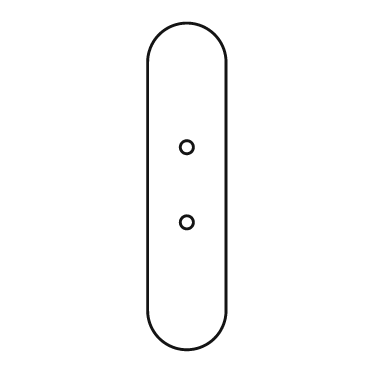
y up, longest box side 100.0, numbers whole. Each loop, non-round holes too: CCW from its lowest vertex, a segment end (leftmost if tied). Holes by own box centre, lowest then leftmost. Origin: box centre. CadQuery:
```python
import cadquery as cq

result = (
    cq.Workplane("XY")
    .moveTo(-12.0, -38.0)
    .threePointArc((0.0, -50.0), (12.0, -38.0))
    .lineTo(12.0, 38.0)
    .threePointArc((0.0, 50.0), (-12.0, 38.0))
    .close()
    .moveTo(0.0, -11.0)
    .circle(2.0)
    .moveTo(0.0, 12.0)
    .circle(2.0)
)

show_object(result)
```